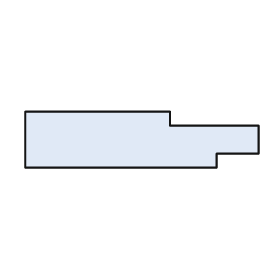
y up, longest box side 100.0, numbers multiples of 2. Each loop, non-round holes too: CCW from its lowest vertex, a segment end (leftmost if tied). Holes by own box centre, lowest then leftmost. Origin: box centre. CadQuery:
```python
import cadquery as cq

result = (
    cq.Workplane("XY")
    .moveTo(-50.0, -12.0)
    .lineTo(32.0, -12.0)
    .lineTo(32.0, -6.0)
    .lineTo(50.0, -6.0)
    .lineTo(50.0, 6.0)
    .lineTo(12.0, 6.0)
    .lineTo(12.0, 12.0)
    .lineTo(-50.0, 12.0)
    .close()
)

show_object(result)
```